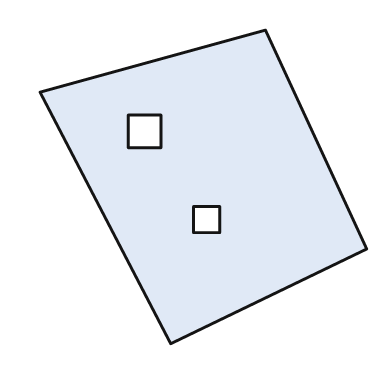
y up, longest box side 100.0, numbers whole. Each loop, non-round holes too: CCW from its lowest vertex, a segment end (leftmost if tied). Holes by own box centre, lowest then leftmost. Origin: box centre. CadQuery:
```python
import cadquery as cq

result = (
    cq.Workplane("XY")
    .moveTo(-10.0, -48.0)
    .lineTo(50.0, -19.0)
    .lineTo(19.0, 48.0)
    .lineTo(-50.0, 29.0)
    .close()
    .moveTo(-3.0, -14.0)
    .lineTo(5.0, -14.0)
    .lineTo(5.0, -6.0)
    .lineTo(-3.0, -6.0)
    .close()
    .moveTo(-23.0, 12.0)
    .lineTo(-13.0, 12.0)
    .lineTo(-13.0, 22.0)
    .lineTo(-23.0, 22.0)
    .close()
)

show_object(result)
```